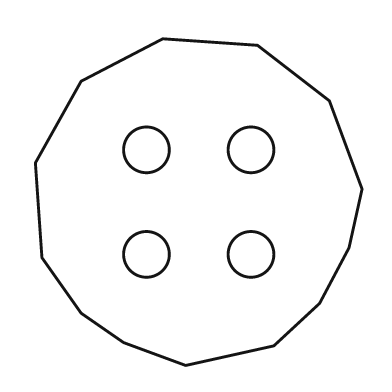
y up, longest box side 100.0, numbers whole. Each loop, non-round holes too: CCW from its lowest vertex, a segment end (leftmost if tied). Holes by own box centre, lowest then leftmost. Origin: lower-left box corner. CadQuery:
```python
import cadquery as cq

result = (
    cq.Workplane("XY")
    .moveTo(46.0, 0.0)
    .lineTo(73.0, 6.0)
    .lineTo(87.0, 19.0)
    .lineTo(96.0, 36.0)
    .lineTo(100.0, 54.0)
    .lineTo(90.0, 81.0)
    .lineTo(68.0, 98.0)
    .lineTo(39.0, 100.0)
    .lineTo(14.0, 87.0)
    .lineTo(0.0, 62.0)
    .lineTo(2.0, 33.0)
    .lineTo(14.0, 16.0)
    .lineTo(27.0, 7.0)
    .close()
    .moveTo(34.0, 34.0)
    .circle(7.0)
    .moveTo(66.0, 34.0)
    .circle(7.0)
    .moveTo(34.0, 66.0)
    .circle(7.0)
    .moveTo(66.0, 66.0)
    .circle(7.0)
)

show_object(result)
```